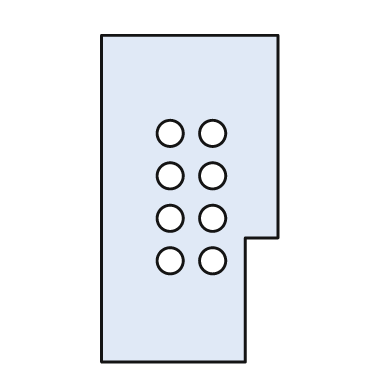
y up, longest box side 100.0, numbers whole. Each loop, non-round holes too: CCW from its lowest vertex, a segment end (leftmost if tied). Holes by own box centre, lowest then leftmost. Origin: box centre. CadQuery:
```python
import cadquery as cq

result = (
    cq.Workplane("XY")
    .moveTo(-27.0, -50.0)
    .lineTo(17.0, -50.0)
    .lineTo(17.0, -12.0)
    .lineTo(27.0, -12.0)
    .lineTo(27.0, 50.0)
    .lineTo(-27.0, 50.0)
    .close()
    .moveTo(-6.0, -19.0)
    .circle(4.0)
    .moveTo(7.0, -19.0)
    .circle(4.0)
    .moveTo(-6.0, -6.0)
    .circle(4.0)
    .moveTo(7.0, -6.0)
    .circle(4.0)
    .moveTo(-6.0, 7.0)
    .circle(4.0)
    .moveTo(7.0, 7.0)
    .circle(4.0)
    .moveTo(-6.0, 20.0)
    .circle(4.0)
    .moveTo(7.0, 20.0)
    .circle(4.0)
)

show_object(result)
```